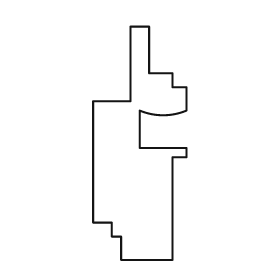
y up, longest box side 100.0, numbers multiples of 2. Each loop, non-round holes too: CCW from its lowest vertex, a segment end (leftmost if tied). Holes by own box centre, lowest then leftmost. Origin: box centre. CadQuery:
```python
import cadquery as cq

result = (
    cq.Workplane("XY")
    .moveTo(-8.0, -50.0)
    .lineTo(14.0, -50.0)
    .lineTo(14.0, -6.0)
    .lineTo(20.0, -6.0)
    .lineTo(20.0, -2.0)
    .lineTo(0.0, -2.0)
    .lineTo(0.0, 14.0)
    .threePointArc((10.0, 12.0), (20.0, 14.0))
    .lineTo(20.0, 24.0)
    .lineTo(14.0, 24.0)
    .lineTo(14.0, 30.0)
    .lineTo(4.0, 30.0)
    .lineTo(4.0, 50.0)
    .lineTo(-4.0, 50.0)
    .lineTo(-4.0, 18.0)
    .lineTo(-20.0, 18.0)
    .lineTo(-20.0, -34.0)
    .lineTo(-12.0, -34.0)
    .lineTo(-12.0, -40.0)
    .lineTo(-8.0, -40.0)
    .close()
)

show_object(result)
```